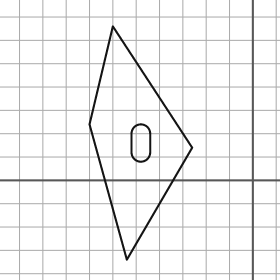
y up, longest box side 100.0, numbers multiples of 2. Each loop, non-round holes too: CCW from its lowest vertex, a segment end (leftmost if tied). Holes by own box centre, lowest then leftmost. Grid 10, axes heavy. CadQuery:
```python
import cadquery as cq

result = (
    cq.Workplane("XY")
    .moveTo(-54.0, -34.0)
    .lineTo(-26.0, 14.0)
    .lineTo(-60.0, 66.0)
    .lineTo(-70.0, 24.0)
    .close()
    .moveTo(-52.0, 12.0)
    .threePointArc((-48.0, 8.0), (-44.0, 12.0))
    .lineTo(-44.0, 20.0)
    .threePointArc((-48.0, 24.0), (-52.0, 20.0))
    .close()
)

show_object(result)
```